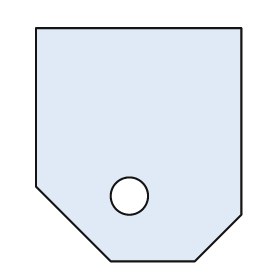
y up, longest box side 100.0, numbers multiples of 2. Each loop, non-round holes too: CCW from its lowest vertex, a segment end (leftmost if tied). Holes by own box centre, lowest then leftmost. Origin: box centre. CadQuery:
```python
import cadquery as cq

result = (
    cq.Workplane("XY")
    .moveTo(-12.0, -50.0)
    .lineTo(24.0, -50.0)
    .lineTo(44.0, -30.0)
    .lineTo(44.0, 50.0)
    .lineTo(-44.0, 50.0)
    .lineTo(-44.0, -18.0)
    .close()
    .moveTo(-4.0, -22.0)
    .circle(8.0)
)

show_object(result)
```